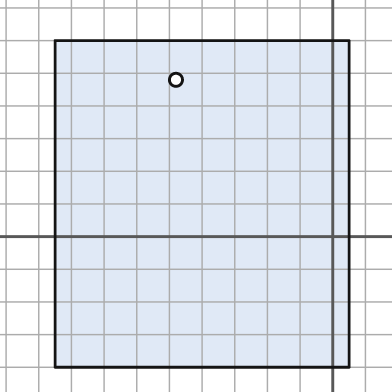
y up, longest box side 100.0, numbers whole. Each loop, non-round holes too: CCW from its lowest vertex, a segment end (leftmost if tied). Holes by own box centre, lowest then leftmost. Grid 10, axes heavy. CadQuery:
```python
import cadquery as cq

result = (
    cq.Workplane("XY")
    .moveTo(-85.0, -40.0)
    .lineTo(5.0, -40.0)
    .lineTo(5.0, 60.0)
    .lineTo(-85.0, 60.0)
    .close()
    .moveTo(-48.0, 48.0)
    .circle(2.0)
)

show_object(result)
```